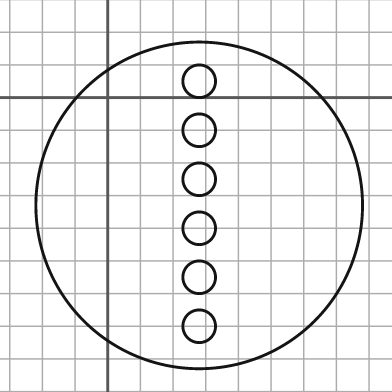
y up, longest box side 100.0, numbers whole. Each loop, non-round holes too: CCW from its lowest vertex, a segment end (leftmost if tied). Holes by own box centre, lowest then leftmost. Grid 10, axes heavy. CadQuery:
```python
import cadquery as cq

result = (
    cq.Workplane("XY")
    .moveTo(28.0, -33.0)
    .circle(50.0)
    .moveTo(28.0, -70.0)
    .circle(5.0)
    .moveTo(28.0, -55.0)
    .circle(5.0)
    .moveTo(28.0, -40.0)
    .circle(5.0)
    .moveTo(28.0, -25.0)
    .circle(5.0)
    .moveTo(28.0, -10.0)
    .circle(5.0)
    .moveTo(28.0, 5.0)
    .circle(5.0)
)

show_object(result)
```